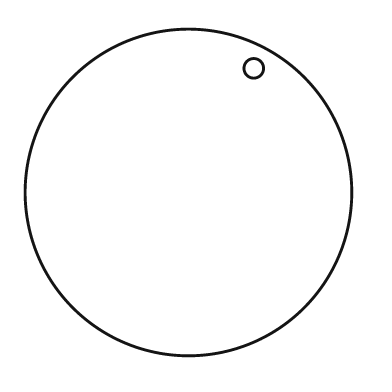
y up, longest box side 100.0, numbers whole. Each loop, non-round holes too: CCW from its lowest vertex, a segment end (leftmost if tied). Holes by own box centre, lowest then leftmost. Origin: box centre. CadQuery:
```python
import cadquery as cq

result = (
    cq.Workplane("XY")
    .moveTo(0.0, 0.0)
    .circle(50.0)
    .moveTo(20.0, 38.0)
    .circle(3.0)
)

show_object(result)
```